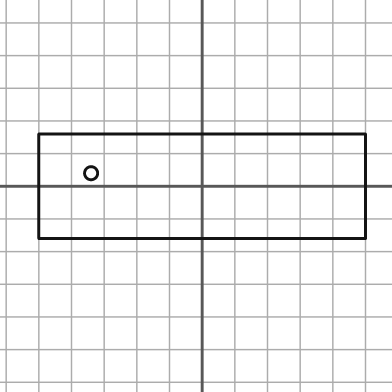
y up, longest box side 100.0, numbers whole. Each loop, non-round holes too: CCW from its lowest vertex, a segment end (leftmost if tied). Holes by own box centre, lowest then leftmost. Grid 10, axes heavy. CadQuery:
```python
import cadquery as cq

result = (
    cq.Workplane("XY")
    .moveTo(-50.0, -16.0)
    .lineTo(50.0, -16.0)
    .lineTo(50.0, 16.0)
    .lineTo(-50.0, 16.0)
    .close()
    .moveTo(-34.0, 4.0)
    .circle(2.0)
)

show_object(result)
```